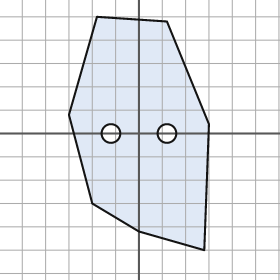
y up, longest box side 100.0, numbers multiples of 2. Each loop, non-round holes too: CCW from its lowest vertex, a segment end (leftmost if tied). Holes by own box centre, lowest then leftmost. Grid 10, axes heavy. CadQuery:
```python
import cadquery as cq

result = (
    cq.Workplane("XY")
    .moveTo(28.0, -50.0)
    .lineTo(30.0, 4.0)
    .lineTo(12.0, 48.0)
    .lineTo(-18.0, 50.0)
    .lineTo(-30.0, 8.0)
    .lineTo(-20.0, -30.0)
    .lineTo(0.0, -42.0)
    .close()
    .moveTo(-12.0, 0.0)
    .circle(4.0)
    .moveTo(12.0, 0.0)
    .circle(4.0)
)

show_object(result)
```